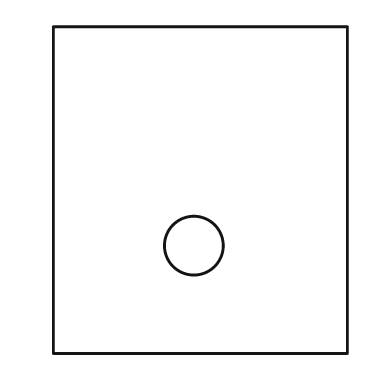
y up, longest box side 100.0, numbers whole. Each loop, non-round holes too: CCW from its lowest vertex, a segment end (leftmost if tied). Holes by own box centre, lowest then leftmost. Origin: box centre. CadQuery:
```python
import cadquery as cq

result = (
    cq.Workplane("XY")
    .moveTo(-45.0, -50.0)
    .lineTo(45.0, -50.0)
    .lineTo(45.0, 50.0)
    .lineTo(-45.0, 50.0)
    .close()
    .moveTo(-2.0, -17.0)
    .circle(9.0)
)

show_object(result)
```